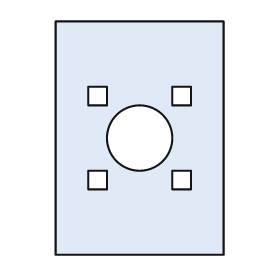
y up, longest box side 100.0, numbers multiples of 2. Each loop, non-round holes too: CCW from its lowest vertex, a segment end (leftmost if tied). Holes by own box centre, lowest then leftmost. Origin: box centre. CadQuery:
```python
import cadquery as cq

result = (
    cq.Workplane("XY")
    .moveTo(-36.0, -50.0)
    .lineTo(36.0, -50.0)
    .lineTo(36.0, 50.0)
    .lineTo(-36.0, 50.0)
    .close()
    .moveTo(-22.0, -22.0)
    .lineTo(-14.0, -22.0)
    .lineTo(-14.0, -14.0)
    .lineTo(-22.0, -14.0)
    .close()
    .moveTo(14.0, -22.0)
    .lineTo(22.0, -22.0)
    .lineTo(22.0, -14.0)
    .lineTo(14.0, -14.0)
    .close()
    .moveTo(0.0, 0.0)
    .circle(14.0)
    .moveTo(-22.0, 14.0)
    .lineTo(-14.0, 14.0)
    .lineTo(-14.0, 22.0)
    .lineTo(-22.0, 22.0)
    .close()
    .moveTo(14.0, 14.0)
    .lineTo(22.0, 14.0)
    .lineTo(22.0, 22.0)
    .lineTo(14.0, 22.0)
    .close()
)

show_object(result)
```